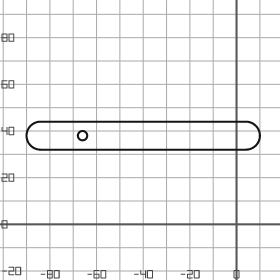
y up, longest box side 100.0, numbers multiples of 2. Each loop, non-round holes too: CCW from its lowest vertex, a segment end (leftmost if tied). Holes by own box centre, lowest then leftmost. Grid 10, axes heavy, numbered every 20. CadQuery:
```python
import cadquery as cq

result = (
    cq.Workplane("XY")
    .moveTo(-84.0, 32.0)
    .lineTo(4.0, 32.0)
    .threePointArc((10.0, 38.0), (4.0, 44.0))
    .lineTo(-84.0, 44.0)
    .threePointArc((-90.0, 38.0), (-84.0, 32.0))
    .close()
    .moveTo(-66.0, 38.0)
    .circle(2.0)
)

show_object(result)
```